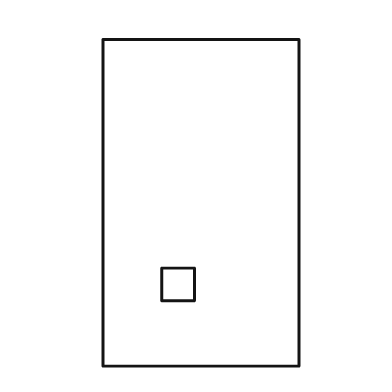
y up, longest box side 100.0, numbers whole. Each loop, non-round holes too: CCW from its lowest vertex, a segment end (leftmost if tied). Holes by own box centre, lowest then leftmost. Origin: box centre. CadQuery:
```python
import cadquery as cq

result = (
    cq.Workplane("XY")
    .moveTo(-30.0, -50.0)
    .lineTo(30.0, -50.0)
    .lineTo(30.0, 50.0)
    .lineTo(-30.0, 50.0)
    .close()
    .moveTo(-12.0, -30.0)
    .lineTo(-2.0, -30.0)
    .lineTo(-2.0, -20.0)
    .lineTo(-12.0, -20.0)
    .close()
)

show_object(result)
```